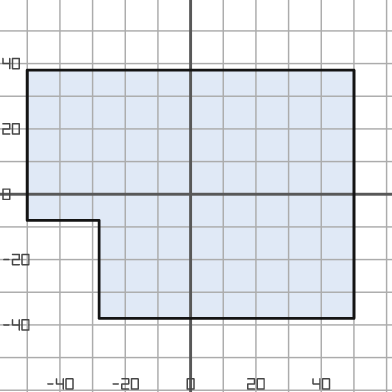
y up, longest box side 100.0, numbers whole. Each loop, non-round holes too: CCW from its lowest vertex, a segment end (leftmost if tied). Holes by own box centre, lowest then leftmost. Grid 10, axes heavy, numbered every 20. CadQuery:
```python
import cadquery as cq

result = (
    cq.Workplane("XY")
    .moveTo(-28.0, -38.0)
    .lineTo(50.0, -38.0)
    .lineTo(50.0, 38.0)
    .lineTo(-50.0, 38.0)
    .lineTo(-50.0, -8.0)
    .lineTo(-28.0, -8.0)
    .close()
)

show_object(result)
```